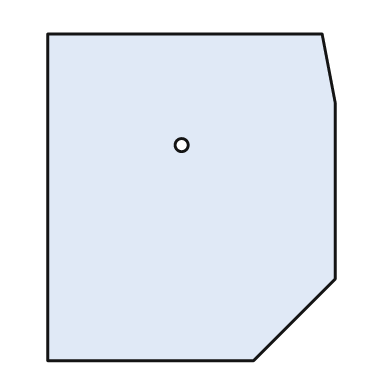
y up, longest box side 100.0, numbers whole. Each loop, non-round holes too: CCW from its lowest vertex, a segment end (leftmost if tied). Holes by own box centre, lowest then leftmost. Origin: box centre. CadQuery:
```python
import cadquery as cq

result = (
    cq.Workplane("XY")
    .moveTo(-44.0, -50.0)
    .lineTo(19.0, -50.0)
    .lineTo(44.0, -25.0)
    .lineTo(44.0, 29.0)
    .lineTo(40.0, 50.0)
    .lineTo(-44.0, 50.0)
    .close()
    .moveTo(-3.0, 16.0)
    .circle(2.0)
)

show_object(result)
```